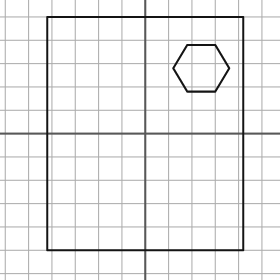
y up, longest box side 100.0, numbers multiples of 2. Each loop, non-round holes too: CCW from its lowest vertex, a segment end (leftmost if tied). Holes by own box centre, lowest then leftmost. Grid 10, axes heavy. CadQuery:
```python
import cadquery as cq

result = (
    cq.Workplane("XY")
    .moveTo(-42.0, -50.0)
    .lineTo(42.0, -50.0)
    .lineTo(42.0, 50.0)
    .lineTo(-42.0, 50.0)
    .close()
    .moveTo(18.0, 18.0)
    .lineTo(30.0, 18.0)
    .lineTo(36.0, 28.0)
    .lineTo(30.0, 38.0)
    .lineTo(18.0, 38.0)
    .lineTo(12.0, 28.0)
    .close()
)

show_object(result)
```